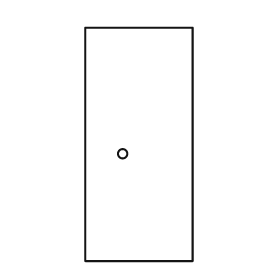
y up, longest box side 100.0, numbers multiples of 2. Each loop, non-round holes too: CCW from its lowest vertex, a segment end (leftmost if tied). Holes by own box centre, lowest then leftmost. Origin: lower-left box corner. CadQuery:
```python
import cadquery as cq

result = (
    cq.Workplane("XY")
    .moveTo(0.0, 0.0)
    .lineTo(46.0, 0.0)
    .lineTo(46.0, 100.0)
    .lineTo(0.0, 100.0)
    .close()
    .moveTo(16.0, 46.0)
    .circle(2.0)
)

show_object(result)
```